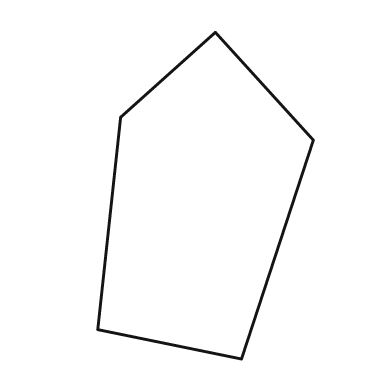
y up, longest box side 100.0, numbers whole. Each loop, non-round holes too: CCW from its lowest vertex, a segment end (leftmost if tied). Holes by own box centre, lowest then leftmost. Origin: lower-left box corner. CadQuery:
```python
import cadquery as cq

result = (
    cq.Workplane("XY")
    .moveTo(44.0, 0.0)
    .lineTo(66.0, 67.0)
    .lineTo(36.0, 100.0)
    .lineTo(7.0, 74.0)
    .lineTo(0.0, 9.0)
    .close()
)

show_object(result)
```